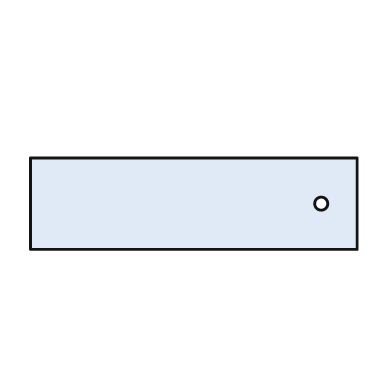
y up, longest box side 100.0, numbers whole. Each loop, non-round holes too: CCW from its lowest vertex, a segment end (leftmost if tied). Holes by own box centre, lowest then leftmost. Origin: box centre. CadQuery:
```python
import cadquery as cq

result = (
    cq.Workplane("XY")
    .moveTo(-50.0, -14.0)
    .lineTo(50.0, -14.0)
    .lineTo(50.0, 14.0)
    .lineTo(-50.0, 14.0)
    .close()
    .moveTo(39.0, 0.0)
    .circle(2.0)
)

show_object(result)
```